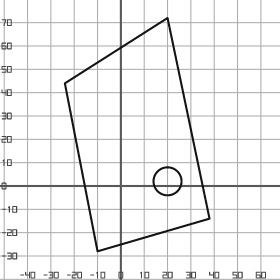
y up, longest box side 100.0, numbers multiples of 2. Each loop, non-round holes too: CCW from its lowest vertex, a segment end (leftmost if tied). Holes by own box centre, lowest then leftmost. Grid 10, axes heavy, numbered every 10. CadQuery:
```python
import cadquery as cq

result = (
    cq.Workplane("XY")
    .moveTo(-10.0, -28.0)
    .lineTo(38.0, -14.0)
    .lineTo(20.0, 72.0)
    .lineTo(-24.0, 44.0)
    .close()
    .moveTo(20.0, 2.0)
    .circle(6.0)
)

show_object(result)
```